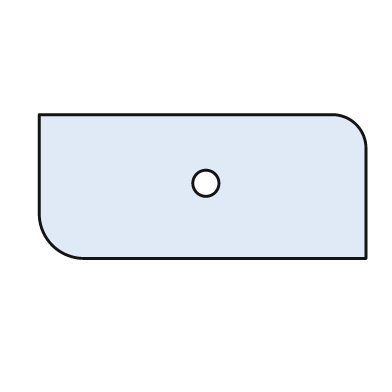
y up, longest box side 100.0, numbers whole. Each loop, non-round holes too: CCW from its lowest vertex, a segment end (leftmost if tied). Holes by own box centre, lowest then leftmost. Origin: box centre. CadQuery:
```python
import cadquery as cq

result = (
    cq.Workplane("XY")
    .moveTo(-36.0, -22.0)
    .lineTo(50.0, -22.0)
    .lineTo(50.0, 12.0)
    .threePointArc((47.0, 19.0), (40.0, 22.0))
    .lineTo(-50.0, 22.0)
    .lineTo(-50.0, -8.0)
    .threePointArc((-46.0, -18.0), (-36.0, -22.0))
    .close()
    .moveTo(1.0, 1.0)
    .circle(4.0)
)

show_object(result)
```